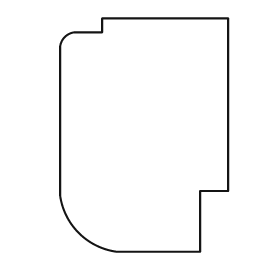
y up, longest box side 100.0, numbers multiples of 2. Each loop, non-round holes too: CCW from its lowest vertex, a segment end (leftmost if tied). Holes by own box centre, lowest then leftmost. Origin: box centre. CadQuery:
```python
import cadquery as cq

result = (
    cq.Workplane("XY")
    .moveTo(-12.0, -50.0)
    .lineTo(24.0, -50.0)
    .lineTo(24.0, -24.0)
    .lineTo(36.0, -24.0)
    .lineTo(36.0, 50.0)
    .lineTo(-18.0, 50.0)
    .lineTo(-18.0, 44.0)
    .lineTo(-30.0, 44.0)
    .threePointArc((-34.0, 42.0), (-36.0, 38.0))
    .lineTo(-36.0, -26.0)
    .threePointArc((-28.0, -42.0), (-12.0, -50.0))
    .close()
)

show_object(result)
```